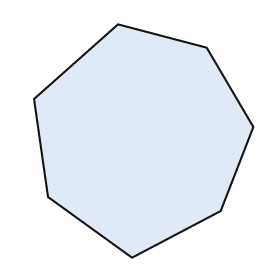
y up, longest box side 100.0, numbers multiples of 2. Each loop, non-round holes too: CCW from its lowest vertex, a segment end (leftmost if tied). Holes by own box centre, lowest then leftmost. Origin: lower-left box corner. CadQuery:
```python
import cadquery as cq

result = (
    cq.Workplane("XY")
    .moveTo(42.0, 0.0)
    .lineTo(80.0, 20.0)
    .lineTo(94.0, 56.0)
    .lineTo(74.0, 90.0)
    .lineTo(36.0, 100.0)
    .lineTo(0.0, 68.0)
    .lineTo(6.0, 26.0)
    .close()
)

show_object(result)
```